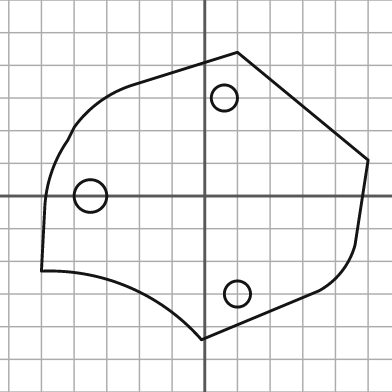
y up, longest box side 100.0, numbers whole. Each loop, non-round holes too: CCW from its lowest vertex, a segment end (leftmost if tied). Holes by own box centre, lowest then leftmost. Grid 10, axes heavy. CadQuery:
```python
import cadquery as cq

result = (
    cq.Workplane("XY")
    .moveTo(-1.0, -44.0)
    .lineTo(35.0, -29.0)
    .threePointArc((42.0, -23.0), (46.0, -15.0))
    .lineTo(50.0, 11.0)
    .lineTo(10.0, 44.0)
    .lineTo(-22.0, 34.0)
    .threePointArc((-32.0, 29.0), (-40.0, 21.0))
    .lineTo(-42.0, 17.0)
    .threePointArc((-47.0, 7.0), (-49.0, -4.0))
    .lineTo(-50.0, -23.0)
    .threePointArc((-23.0, -28.0), (-1.0, -44.0))
    .close()
    .moveTo(10.0, -30.0)
    .circle(4.0)
    .moveTo(-35.0, 0.0)
    .circle(5.0)
    .moveTo(6.0, 30.0)
    .circle(4.0)
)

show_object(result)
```